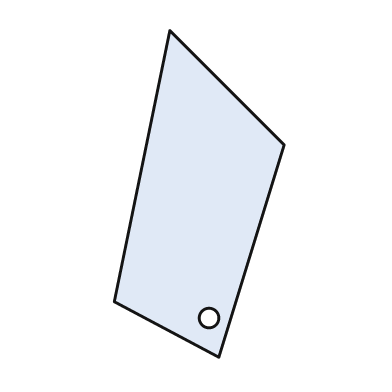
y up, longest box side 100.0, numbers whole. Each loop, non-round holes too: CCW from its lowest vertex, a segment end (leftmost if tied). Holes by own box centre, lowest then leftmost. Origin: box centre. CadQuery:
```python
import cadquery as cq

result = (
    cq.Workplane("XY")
    .moveTo(6.0, -50.0)
    .lineTo(26.0, 15.0)
    .lineTo(-9.0, 50.0)
    .lineTo(-26.0, -33.0)
    .close()
    .moveTo(3.0, -38.0)
    .circle(3.0)
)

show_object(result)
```